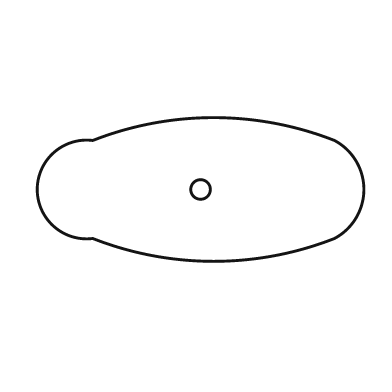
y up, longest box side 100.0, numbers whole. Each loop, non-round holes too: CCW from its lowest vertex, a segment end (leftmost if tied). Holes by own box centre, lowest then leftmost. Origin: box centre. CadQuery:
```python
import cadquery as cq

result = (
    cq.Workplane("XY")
    .moveTo(-33.0, -15.0)
    .threePointArc((4.0, -22.0), (41.0, -15.0))
    .threePointArc((50.0, 0.0), (41.0, 15.0))
    .threePointArc((4.0, 22.0), (-33.0, 15.0))
    .threePointArc((-50.0, 0.0), (-33.0, -15.0))
    .close()
    .moveTo(0.0, 0.0)
    .circle(3.0)
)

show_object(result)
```